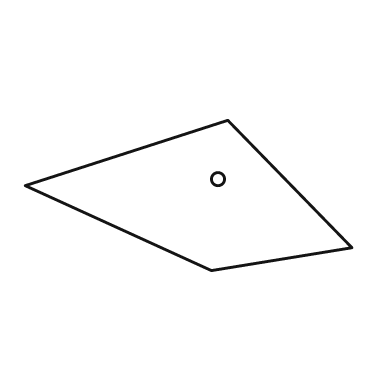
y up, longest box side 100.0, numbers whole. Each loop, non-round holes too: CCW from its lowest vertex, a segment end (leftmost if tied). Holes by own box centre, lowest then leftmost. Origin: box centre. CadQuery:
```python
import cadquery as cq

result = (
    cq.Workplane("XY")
    .moveTo(7.0, -23.0)
    .lineTo(50.0, -16.0)
    .lineTo(12.0, 23.0)
    .lineTo(-50.0, 3.0)
    .close()
    .moveTo(9.0, 5.0)
    .circle(2.0)
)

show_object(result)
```